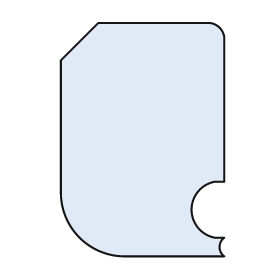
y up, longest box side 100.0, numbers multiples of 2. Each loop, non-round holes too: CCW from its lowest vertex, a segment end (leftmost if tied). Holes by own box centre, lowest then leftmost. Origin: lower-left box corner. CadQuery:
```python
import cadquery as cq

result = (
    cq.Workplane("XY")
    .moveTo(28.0, 0.0)
    .lineTo(70.0, 0.0)
    .threePointArc((68.0, 4.0), (70.0, 8.0))
    .lineTo(66.0, 8.0)
    .threePointArc((56.0, 20.0), (66.0, 32.0))
    .lineTo(70.0, 32.0)
    .lineTo(70.0, 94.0)
    .threePointArc((68.0, 98.0), (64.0, 100.0))
    .lineTo(16.0, 100.0)
    .lineTo(0.0, 84.0)
    .lineTo(0.0, 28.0)
    .threePointArc((8.0, 8.0), (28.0, 0.0))
    .close()
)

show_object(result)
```